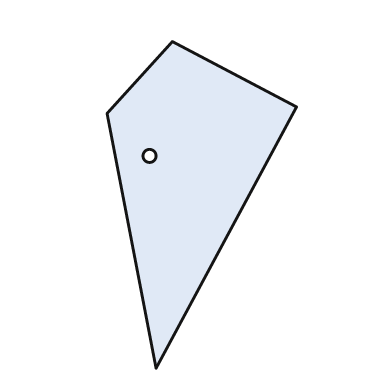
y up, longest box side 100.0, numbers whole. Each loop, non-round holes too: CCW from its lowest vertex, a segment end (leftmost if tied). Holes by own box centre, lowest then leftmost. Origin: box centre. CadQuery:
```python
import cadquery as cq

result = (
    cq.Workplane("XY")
    .moveTo(-14.0, -50.0)
    .lineTo(29.0, 30.0)
    .lineTo(-9.0, 50.0)
    .lineTo(-29.0, 28.0)
    .close()
    .moveTo(-16.0, 15.0)
    .circle(2.0)
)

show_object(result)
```